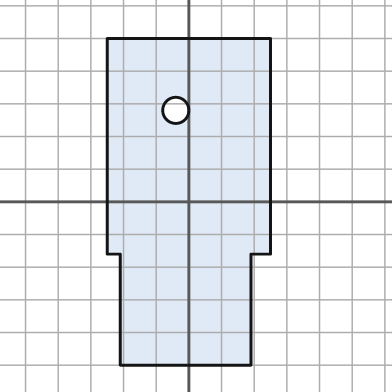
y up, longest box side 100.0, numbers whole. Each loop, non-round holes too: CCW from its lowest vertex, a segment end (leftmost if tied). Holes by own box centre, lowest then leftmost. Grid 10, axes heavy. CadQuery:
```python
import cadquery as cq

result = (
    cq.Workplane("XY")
    .moveTo(-21.0, -50.0)
    .lineTo(19.0, -50.0)
    .lineTo(19.0, -16.0)
    .lineTo(25.0, -16.0)
    .lineTo(25.0, 50.0)
    .lineTo(-25.0, 50.0)
    .lineTo(-25.0, -16.0)
    .lineTo(-21.0, -16.0)
    .close()
    .moveTo(-4.0, 28.0)
    .circle(4.0)
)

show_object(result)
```